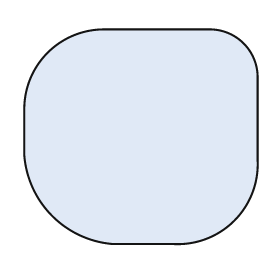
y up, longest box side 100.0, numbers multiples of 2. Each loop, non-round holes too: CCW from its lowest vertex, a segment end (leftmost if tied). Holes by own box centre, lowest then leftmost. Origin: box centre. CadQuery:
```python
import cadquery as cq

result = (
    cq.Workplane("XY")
    .moveTo(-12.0, -46.0)
    .lineTo(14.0, -46.0)
    .threePointArc((40.0, -36.0), (50.0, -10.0))
    .lineTo(50.0, 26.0)
    .threePointArc((44.0, 40.0), (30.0, 46.0))
    .lineTo(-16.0, 46.0)
    .threePointArc((-40.0, 36.0), (-50.0, 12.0))
    .lineTo(-50.0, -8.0)
    .threePointArc((-38.0, -34.0), (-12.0, -46.0))
    .close()
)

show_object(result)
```